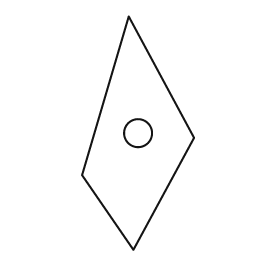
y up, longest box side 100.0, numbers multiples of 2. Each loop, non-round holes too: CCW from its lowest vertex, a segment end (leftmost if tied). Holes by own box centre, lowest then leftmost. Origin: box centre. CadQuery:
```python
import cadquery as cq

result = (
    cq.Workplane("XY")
    .moveTo(-2.0, -50.0)
    .lineTo(24.0, -2.0)
    .lineTo(-4.0, 50.0)
    .lineTo(-24.0, -18.0)
    .close()
    .moveTo(0.0, 0.0)
    .circle(6.0)
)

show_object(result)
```